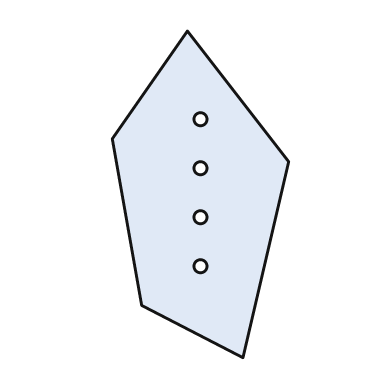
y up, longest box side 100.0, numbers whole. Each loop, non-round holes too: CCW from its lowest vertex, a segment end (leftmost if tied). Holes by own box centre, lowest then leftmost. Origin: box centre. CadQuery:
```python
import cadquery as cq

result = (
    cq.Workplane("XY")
    .moveTo(13.0, -50.0)
    .lineTo(27.0, 10.0)
    .lineTo(-4.0, 50.0)
    .lineTo(-27.0, 17.0)
    .lineTo(-18.0, -34.0)
    .close()
    .moveTo(0.0, -22.0)
    .circle(2.0)
    .moveTo(0.0, -7.0)
    .circle(2.0)
    .moveTo(0.0, 8.0)
    .circle(2.0)
    .moveTo(0.0, 23.0)
    .circle(2.0)
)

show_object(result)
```